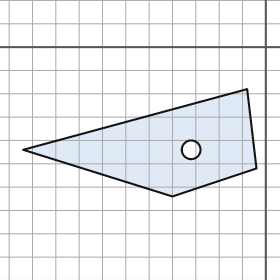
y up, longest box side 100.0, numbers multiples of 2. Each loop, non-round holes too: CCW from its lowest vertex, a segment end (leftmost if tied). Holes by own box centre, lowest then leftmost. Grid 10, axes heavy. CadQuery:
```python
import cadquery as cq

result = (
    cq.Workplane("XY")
    .moveTo(-40.0, -64.0)
    .lineTo(-4.0, -52.0)
    .lineTo(-8.0, -18.0)
    .lineTo(-104.0, -44.0)
    .close()
    .moveTo(-32.0, -44.0)
    .circle(4.0)
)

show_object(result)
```